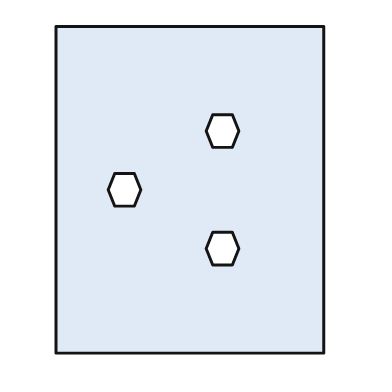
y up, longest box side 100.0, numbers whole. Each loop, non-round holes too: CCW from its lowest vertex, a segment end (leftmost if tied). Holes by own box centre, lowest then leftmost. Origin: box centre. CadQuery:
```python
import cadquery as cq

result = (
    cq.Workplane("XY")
    .moveTo(-41.0, -50.0)
    .lineTo(41.0, -50.0)
    .lineTo(41.0, 50.0)
    .lineTo(-41.0, 50.0)
    .close()
    .moveTo(7.0, -23.0)
    .lineTo(13.0, -23.0)
    .lineTo(15.0, -18.0)
    .lineTo(13.0, -13.0)
    .lineTo(7.0, -13.0)
    .lineTo(5.0, -18.0)
    .close()
    .moveTo(-23.0, -5.0)
    .lineTo(-17.0, -5.0)
    .lineTo(-15.0, 0.0)
    .lineTo(-17.0, 5.0)
    .lineTo(-23.0, 5.0)
    .lineTo(-25.0, 0.0)
    .close()
    .moveTo(7.0, 13.0)
    .lineTo(13.0, 13.0)
    .lineTo(15.0, 18.0)
    .lineTo(13.0, 23.0)
    .lineTo(7.0, 23.0)
    .lineTo(5.0, 18.0)
    .close()
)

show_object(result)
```